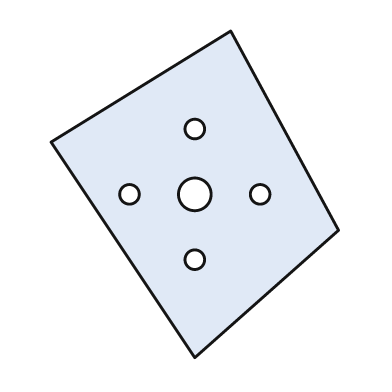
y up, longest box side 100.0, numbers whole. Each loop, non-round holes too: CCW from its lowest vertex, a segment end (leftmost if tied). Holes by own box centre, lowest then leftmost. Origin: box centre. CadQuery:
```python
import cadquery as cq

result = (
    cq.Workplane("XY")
    .moveTo(0.0, -50.0)
    .lineTo(44.0, -11.0)
    .lineTo(11.0, 50.0)
    .lineTo(-44.0, 16.0)
    .close()
    .moveTo(0.0, -20.0)
    .circle(3.0)
    .moveTo(-20.0, 0.0)
    .circle(3.0)
    .moveTo(0.0, 0.0)
    .circle(5.0)
    .moveTo(20.0, 0.0)
    .circle(3.0)
    .moveTo(0.0, 20.0)
    .circle(3.0)
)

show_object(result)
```